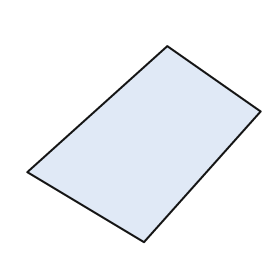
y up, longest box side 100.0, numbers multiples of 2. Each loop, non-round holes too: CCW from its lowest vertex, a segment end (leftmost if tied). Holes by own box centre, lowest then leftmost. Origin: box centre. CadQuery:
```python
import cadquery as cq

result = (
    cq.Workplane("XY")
    .moveTo(0.0, -42.0)
    .lineTo(50.0, 14.0)
    .lineTo(10.0, 42.0)
    .lineTo(-50.0, -12.0)
    .close()
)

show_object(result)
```